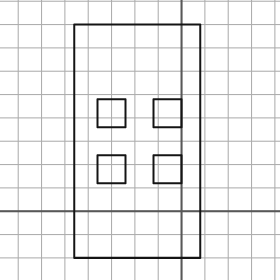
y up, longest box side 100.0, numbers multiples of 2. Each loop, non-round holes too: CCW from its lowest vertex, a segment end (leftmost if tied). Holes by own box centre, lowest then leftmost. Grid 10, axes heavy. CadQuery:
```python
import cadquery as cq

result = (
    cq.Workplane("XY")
    .moveTo(-46.0, -20.0)
    .lineTo(8.0, -20.0)
    .lineTo(8.0, 80.0)
    .lineTo(-46.0, 80.0)
    .close()
    .moveTo(-36.0, 12.0)
    .lineTo(-24.0, 12.0)
    .lineTo(-24.0, 24.0)
    .lineTo(-36.0, 24.0)
    .close()
    .moveTo(-12.0, 12.0)
    .lineTo(0.0, 12.0)
    .lineTo(0.0, 24.0)
    .lineTo(-12.0, 24.0)
    .close()
    .moveTo(-36.0, 36.0)
    .lineTo(-24.0, 36.0)
    .lineTo(-24.0, 48.0)
    .lineTo(-36.0, 48.0)
    .close()
    .moveTo(-12.0, 36.0)
    .lineTo(0.0, 36.0)
    .lineTo(0.0, 48.0)
    .lineTo(-12.0, 48.0)
    .close()
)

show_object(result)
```